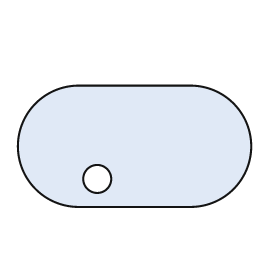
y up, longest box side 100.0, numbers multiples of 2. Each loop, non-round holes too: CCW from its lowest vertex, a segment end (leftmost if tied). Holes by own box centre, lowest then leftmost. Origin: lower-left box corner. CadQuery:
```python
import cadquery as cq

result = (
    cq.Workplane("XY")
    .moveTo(26.0, 0.0)
    .lineTo(74.0, 0.0)
    .threePointArc((100.0, 26.0), (74.0, 52.0))
    .lineTo(26.0, 52.0)
    .threePointArc((0.0, 26.0), (26.0, 0.0))
    .close()
    .moveTo(34.0, 12.0)
    .circle(6.0)
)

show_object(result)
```